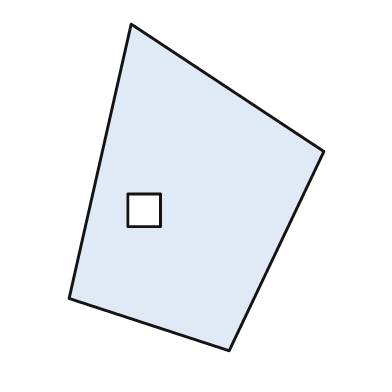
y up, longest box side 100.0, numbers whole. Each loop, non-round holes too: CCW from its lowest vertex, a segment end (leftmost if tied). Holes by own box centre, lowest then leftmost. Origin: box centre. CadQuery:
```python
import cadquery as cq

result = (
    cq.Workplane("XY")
    .moveTo(10.0, -50.0)
    .lineTo(39.0, 11.0)
    .lineTo(-20.0, 50.0)
    .lineTo(-39.0, -34.0)
    .close()
    .moveTo(-21.0, -12.0)
    .lineTo(-11.0, -12.0)
    .lineTo(-11.0, -2.0)
    .lineTo(-21.0, -2.0)
    .close()
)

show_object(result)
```